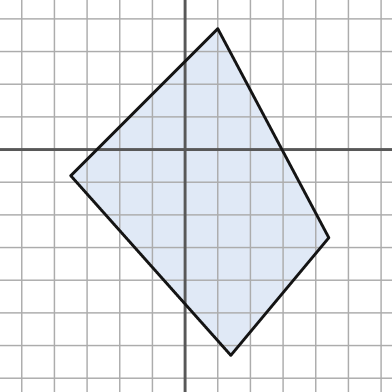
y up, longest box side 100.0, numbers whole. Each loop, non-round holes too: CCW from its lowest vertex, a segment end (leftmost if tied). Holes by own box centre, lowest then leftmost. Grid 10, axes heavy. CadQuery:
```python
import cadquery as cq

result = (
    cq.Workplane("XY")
    .moveTo(14.0, -63.0)
    .lineTo(44.0, -27.0)
    .lineTo(10.0, 37.0)
    .lineTo(-35.0, -8.0)
    .close()
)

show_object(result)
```